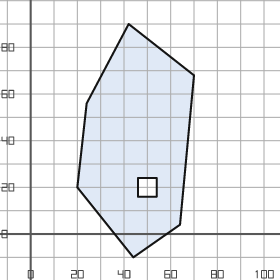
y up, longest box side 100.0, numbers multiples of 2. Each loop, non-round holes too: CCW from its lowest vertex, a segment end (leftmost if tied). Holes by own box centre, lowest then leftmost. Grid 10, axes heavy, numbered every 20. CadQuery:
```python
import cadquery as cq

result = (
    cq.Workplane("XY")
    .moveTo(44.0, -10.0)
    .lineTo(64.0, 4.0)
    .lineTo(70.0, 68.0)
    .lineTo(42.0, 90.0)
    .lineTo(24.0, 56.0)
    .lineTo(20.0, 20.0)
    .close()
    .moveTo(46.0, 16.0)
    .lineTo(54.0, 16.0)
    .lineTo(54.0, 24.0)
    .lineTo(46.0, 24.0)
    .close()
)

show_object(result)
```